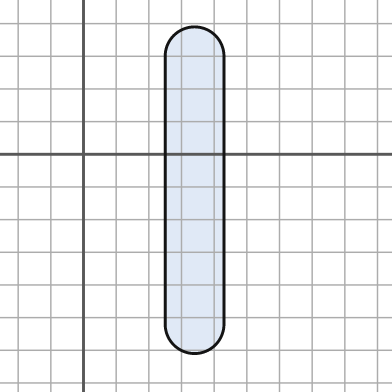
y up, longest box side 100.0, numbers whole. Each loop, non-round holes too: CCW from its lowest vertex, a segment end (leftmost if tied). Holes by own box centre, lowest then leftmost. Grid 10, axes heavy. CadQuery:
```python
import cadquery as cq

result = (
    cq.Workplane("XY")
    .moveTo(25.0, -52.0)
    .threePointArc((34.0, -61.0), (43.0, -52.0))
    .lineTo(43.0, 30.0)
    .threePointArc((34.0, 39.0), (25.0, 30.0))
    .close()
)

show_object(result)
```